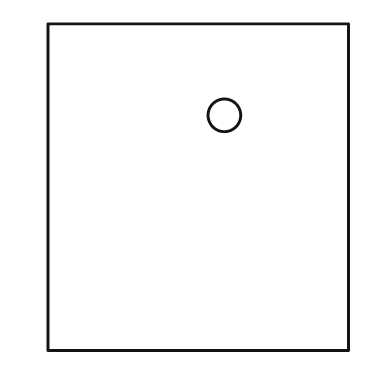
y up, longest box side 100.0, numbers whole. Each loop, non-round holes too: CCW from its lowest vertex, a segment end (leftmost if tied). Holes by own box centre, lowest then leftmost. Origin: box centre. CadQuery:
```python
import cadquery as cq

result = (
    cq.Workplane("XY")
    .moveTo(-46.0, -50.0)
    .lineTo(46.0, -50.0)
    .lineTo(46.0, 50.0)
    .lineTo(-46.0, 50.0)
    .close()
    .moveTo(8.0, 22.0)
    .circle(5.0)
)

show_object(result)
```